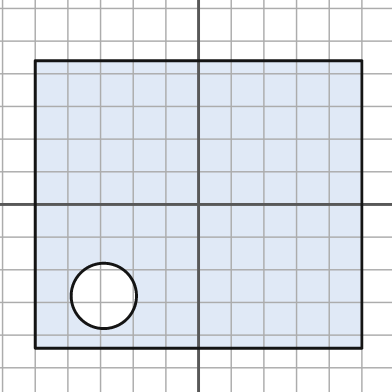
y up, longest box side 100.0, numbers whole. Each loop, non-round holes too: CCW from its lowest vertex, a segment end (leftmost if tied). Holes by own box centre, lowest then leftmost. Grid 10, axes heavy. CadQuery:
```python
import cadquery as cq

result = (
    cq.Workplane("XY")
    .moveTo(-50.0, -44.0)
    .lineTo(50.0, -44.0)
    .lineTo(50.0, 44.0)
    .lineTo(-50.0, 44.0)
    .close()
    .moveTo(-29.0, -28.0)
    .circle(10.0)
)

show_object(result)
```